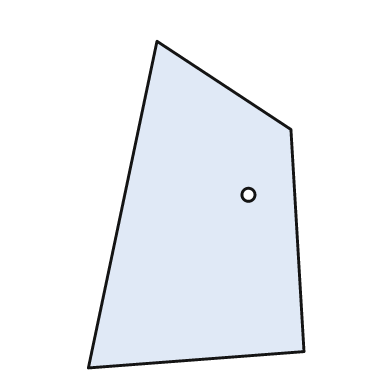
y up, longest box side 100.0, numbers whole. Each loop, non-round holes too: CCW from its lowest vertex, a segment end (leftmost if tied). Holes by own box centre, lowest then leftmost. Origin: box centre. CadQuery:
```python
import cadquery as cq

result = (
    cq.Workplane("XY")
    .moveTo(-33.0, -50.0)
    .lineTo(33.0, -45.0)
    .lineTo(29.0, 23.0)
    .lineTo(-12.0, 50.0)
    .close()
    .moveTo(16.0, 3.0)
    .circle(2.0)
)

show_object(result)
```